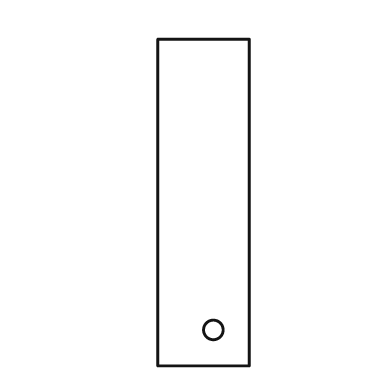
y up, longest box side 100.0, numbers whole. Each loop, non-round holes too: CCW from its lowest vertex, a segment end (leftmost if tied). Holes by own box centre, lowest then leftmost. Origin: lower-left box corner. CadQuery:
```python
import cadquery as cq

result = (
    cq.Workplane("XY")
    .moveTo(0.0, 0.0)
    .lineTo(28.0, 0.0)
    .lineTo(28.0, 100.0)
    .lineTo(0.0, 100.0)
    .close()
    .moveTo(17.0, 11.0)
    .circle(3.0)
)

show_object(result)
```